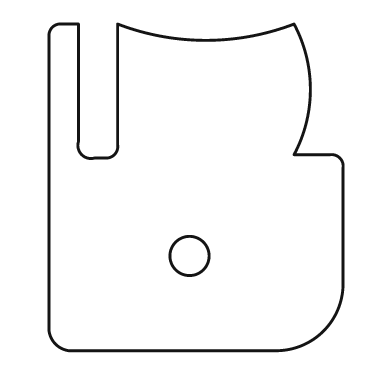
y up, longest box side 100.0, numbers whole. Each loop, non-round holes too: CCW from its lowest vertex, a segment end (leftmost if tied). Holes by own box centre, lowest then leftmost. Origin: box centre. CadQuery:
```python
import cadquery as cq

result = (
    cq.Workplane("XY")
    .moveTo(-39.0, -50.0)
    .lineTo(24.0, -50.0)
    .threePointArc((39.0, -44.0), (45.0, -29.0))
    .lineTo(45.0, 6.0)
    .threePointArc((44.0, 9.0), (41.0, 10.0))
    .lineTo(30.0, 10.0)
    .threePointArc((35.0, 30.0), (30.0, 50.0))
    .threePointArc((3.0, 45.0), (-24.0, 50.0))
    .lineTo(-24.0, 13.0)
    .threePointArc((-25.0, 10.0), (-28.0, 9.0))
    .lineTo(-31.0, 9.0)
    .threePointArc((-35.0, 10.0), (-36.0, 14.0))
    .lineTo(-36.0, 50.0)
    .lineTo(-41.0, 50.0)
    .threePointArc((-44.0, 49.0), (-45.0, 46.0))
    .lineTo(-45.0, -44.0)
    .threePointArc((-43.0, -48.0), (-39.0, -50.0))
    .close()
    .moveTo(-2.0, -21.0)
    .circle(6.0)
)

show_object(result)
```